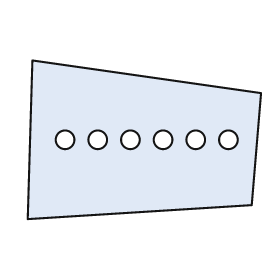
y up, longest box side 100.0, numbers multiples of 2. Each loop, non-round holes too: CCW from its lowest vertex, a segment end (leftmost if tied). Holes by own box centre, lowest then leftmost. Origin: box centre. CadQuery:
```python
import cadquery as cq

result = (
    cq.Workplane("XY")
    .moveTo(-50.0, -34.0)
    .lineTo(46.0, -28.0)
    .lineTo(50.0, 20.0)
    .lineTo(-48.0, 34.0)
    .close()
    .moveTo(-34.0, 0.0)
    .circle(4.0)
    .moveTo(-20.0, 0.0)
    .circle(4.0)
    .moveTo(-6.0, 0.0)
    .circle(4.0)
    .moveTo(8.0, 0.0)
    .circle(4.0)
    .moveTo(22.0, 0.0)
    .circle(4.0)
    .moveTo(36.0, 0.0)
    .circle(4.0)
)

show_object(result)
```